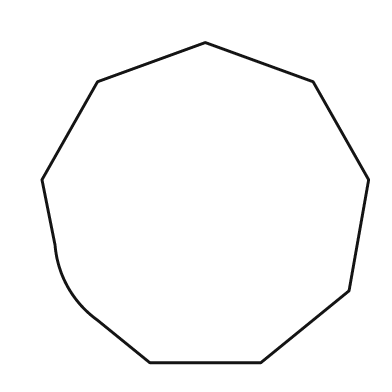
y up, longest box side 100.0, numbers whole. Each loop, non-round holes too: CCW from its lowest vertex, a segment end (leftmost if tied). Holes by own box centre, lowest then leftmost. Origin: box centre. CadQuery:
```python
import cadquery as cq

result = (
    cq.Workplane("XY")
    .moveTo(-17.0, -49.0)
    .lineTo(17.0, -49.0)
    .lineTo(44.0, -27.0)
    .lineTo(50.0, 7.0)
    .lineTo(33.0, 37.0)
    .lineTo(0.0, 49.0)
    .lineTo(-33.0, 37.0)
    .lineTo(-50.0, 7.0)
    .lineTo(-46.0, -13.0)
    .threePointArc((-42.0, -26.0), (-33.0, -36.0))
    .close()
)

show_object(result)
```